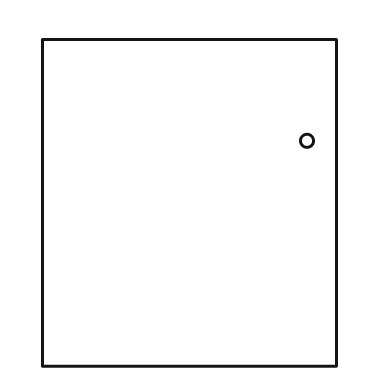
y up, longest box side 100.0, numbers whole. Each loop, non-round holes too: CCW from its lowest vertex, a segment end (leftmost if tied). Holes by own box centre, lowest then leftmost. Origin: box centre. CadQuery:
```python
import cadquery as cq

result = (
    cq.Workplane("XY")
    .moveTo(-45.0, -50.0)
    .lineTo(45.0, -50.0)
    .lineTo(45.0, 50.0)
    .lineTo(-45.0, 50.0)
    .close()
    .moveTo(36.0, 19.0)
    .circle(2.0)
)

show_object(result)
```